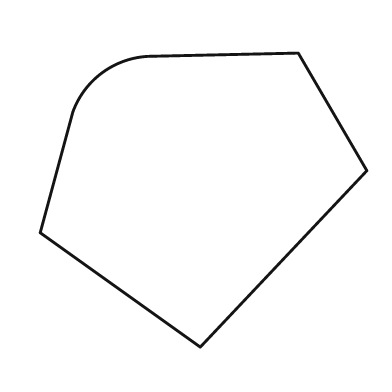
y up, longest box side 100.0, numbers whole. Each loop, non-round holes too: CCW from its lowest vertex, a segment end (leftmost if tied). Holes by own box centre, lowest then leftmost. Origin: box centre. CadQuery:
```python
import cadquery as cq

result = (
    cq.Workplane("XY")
    .moveTo(-1.0, -45.0)
    .lineTo(50.0, 9.0)
    .lineTo(29.0, 45.0)
    .lineTo(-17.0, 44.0)
    .threePointArc((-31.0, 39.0), (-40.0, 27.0))
    .lineTo(-50.0, -10.0)
    .close()
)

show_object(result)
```